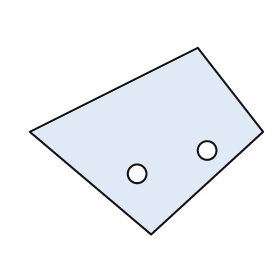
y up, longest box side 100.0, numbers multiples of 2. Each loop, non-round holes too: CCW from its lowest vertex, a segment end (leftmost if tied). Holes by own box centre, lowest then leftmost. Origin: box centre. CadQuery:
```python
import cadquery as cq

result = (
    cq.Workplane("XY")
    .moveTo(2.0, -40.0)
    .lineTo(50.0, 4.0)
    .lineTo(22.0, 40.0)
    .lineTo(-50.0, 4.0)
    .close()
    .moveTo(-4.0, -14.0)
    .circle(4.0)
    .moveTo(26.0, -4.0)
    .circle(4.0)
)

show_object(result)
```